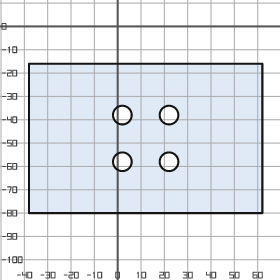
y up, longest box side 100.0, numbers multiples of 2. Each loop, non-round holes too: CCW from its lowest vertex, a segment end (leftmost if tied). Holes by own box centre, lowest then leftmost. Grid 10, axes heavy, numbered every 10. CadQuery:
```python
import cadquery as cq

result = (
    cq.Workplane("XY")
    .moveTo(-38.0, -80.0)
    .lineTo(62.0, -80.0)
    .lineTo(62.0, -16.0)
    .lineTo(-38.0, -16.0)
    .close()
    .moveTo(2.0, -58.0)
    .circle(4.0)
    .moveTo(22.0, -58.0)
    .circle(4.0)
    .moveTo(2.0, -38.0)
    .circle(4.0)
    .moveTo(22.0, -38.0)
    .circle(4.0)
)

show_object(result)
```